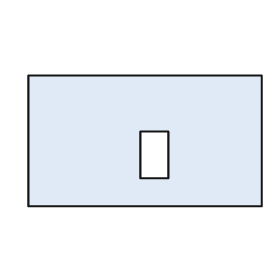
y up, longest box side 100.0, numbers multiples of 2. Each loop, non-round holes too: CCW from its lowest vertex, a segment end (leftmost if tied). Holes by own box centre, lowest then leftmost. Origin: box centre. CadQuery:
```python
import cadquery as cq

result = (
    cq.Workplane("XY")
    .moveTo(-50.0, -28.0)
    .lineTo(50.0, -28.0)
    .lineTo(50.0, 28.0)
    .lineTo(-50.0, 28.0)
    .close()
    .moveTo(-2.0, -16.0)
    .lineTo(10.0, -16.0)
    .lineTo(10.0, 4.0)
    .lineTo(-2.0, 4.0)
    .close()
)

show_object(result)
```